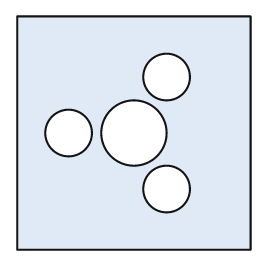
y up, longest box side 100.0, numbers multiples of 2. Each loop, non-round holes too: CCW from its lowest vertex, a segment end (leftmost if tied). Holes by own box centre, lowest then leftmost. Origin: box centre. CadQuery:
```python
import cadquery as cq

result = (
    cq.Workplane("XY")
    .moveTo(-50.0, -50.0)
    .lineTo(50.0, -50.0)
    .lineTo(50.0, 50.0)
    .lineTo(-50.0, 50.0)
    .close()
    .moveTo(14.0, -24.0)
    .circle(10.0)
    .moveTo(-28.0, 0.0)
    .circle(10.0)
    .moveTo(0.0, 0.0)
    .circle(14.0)
    .moveTo(14.0, 24.0)
    .circle(10.0)
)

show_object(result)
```